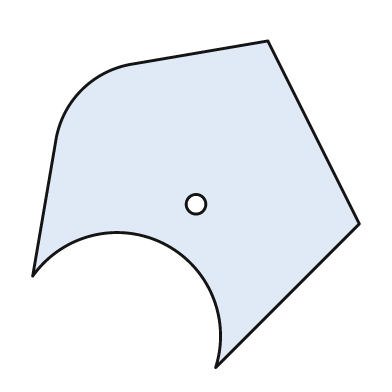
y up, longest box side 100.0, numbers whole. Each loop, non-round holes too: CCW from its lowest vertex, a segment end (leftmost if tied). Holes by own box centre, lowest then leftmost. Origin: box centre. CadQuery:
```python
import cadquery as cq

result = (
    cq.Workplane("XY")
    .moveTo(6.0, -50.0)
    .lineTo(50.0, -6.0)
    .lineTo(22.0, 50.0)
    .lineTo(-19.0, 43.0)
    .threePointArc((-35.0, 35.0), (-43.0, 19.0))
    .lineTo(-50.0, -22.0)
    .threePointArc((-10.0, -12.0), (6.0, -50.0))
    .close()
    .moveTo(0.0, 0.0)
    .circle(3.0)
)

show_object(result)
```